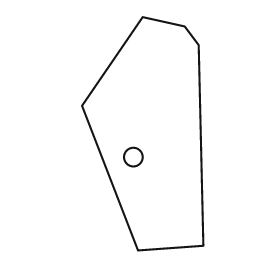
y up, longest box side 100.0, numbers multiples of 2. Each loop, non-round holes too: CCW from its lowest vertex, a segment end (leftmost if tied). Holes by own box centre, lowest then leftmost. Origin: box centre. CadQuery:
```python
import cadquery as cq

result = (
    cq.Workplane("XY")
    .moveTo(-2.0, -50.0)
    .lineTo(26.0, -48.0)
    .lineTo(24.0, 38.0)
    .lineTo(18.0, 46.0)
    .lineTo(0.0, 50.0)
    .lineTo(-26.0, 12.0)
    .close()
    .moveTo(-4.0, -10.0)
    .circle(4.0)
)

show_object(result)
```